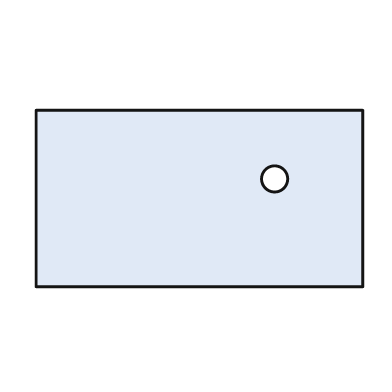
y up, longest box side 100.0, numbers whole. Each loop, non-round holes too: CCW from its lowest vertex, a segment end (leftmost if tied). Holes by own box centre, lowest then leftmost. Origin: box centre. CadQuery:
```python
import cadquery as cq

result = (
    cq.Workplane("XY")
    .moveTo(-50.0, -27.0)
    .lineTo(50.0, -27.0)
    .lineTo(50.0, 27.0)
    .lineTo(-50.0, 27.0)
    .close()
    .moveTo(23.0, 6.0)
    .circle(4.0)
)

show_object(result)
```